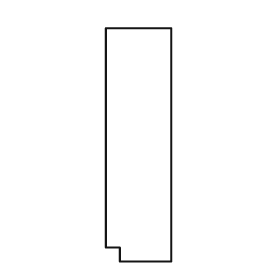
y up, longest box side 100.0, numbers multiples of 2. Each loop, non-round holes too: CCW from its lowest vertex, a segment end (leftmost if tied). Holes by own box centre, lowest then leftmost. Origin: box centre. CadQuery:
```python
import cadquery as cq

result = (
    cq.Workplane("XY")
    .moveTo(-8.0, -50.0)
    .lineTo(14.0, -50.0)
    .lineTo(14.0, 50.0)
    .lineTo(-14.0, 50.0)
    .lineTo(-14.0, -44.0)
    .lineTo(-8.0, -44.0)
    .close()
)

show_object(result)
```